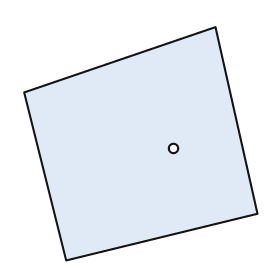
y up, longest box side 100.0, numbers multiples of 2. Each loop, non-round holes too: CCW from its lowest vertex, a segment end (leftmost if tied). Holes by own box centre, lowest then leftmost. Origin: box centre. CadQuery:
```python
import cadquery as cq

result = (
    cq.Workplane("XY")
    .moveTo(-32.0, -50.0)
    .lineTo(50.0, -30.0)
    .lineTo(32.0, 50.0)
    .lineTo(-50.0, 22.0)
    .close()
    .moveTo(14.0, -2.0)
    .circle(2.0)
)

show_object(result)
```